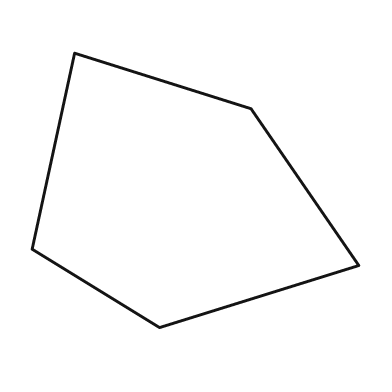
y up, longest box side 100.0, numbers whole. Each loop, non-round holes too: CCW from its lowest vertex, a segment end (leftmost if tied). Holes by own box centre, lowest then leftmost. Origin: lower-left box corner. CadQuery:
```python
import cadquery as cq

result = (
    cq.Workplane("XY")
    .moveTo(39.0, 0.0)
    .lineTo(100.0, 19.0)
    .lineTo(67.0, 67.0)
    .lineTo(13.0, 84.0)
    .lineTo(0.0, 24.0)
    .close()
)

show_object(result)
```